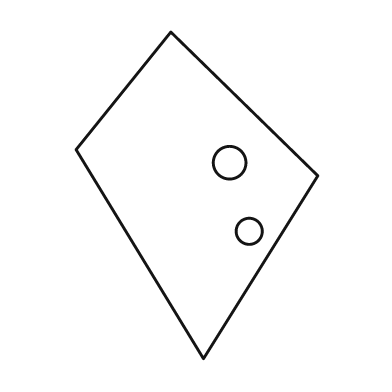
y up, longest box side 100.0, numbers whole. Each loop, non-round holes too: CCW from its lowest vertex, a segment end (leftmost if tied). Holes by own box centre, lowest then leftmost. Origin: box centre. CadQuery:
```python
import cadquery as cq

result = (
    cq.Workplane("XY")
    .moveTo(2.0, -50.0)
    .lineTo(37.0, 6.0)
    .lineTo(-8.0, 50.0)
    .lineTo(-37.0, 14.0)
    .close()
    .moveTo(16.0, -11.0)
    .circle(4.0)
    .moveTo(10.0, 10.0)
    .circle(5.0)
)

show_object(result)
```